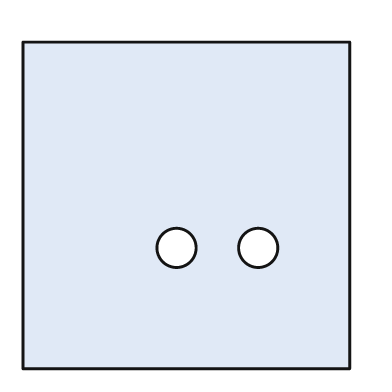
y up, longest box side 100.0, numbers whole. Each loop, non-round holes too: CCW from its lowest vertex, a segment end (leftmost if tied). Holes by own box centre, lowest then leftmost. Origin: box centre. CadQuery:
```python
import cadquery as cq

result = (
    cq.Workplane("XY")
    .moveTo(-50.0, -50.0)
    .lineTo(50.0, -50.0)
    .lineTo(50.0, 50.0)
    .lineTo(-50.0, 50.0)
    .close()
    .moveTo(-3.0, -13.0)
    .circle(6.0)
    .moveTo(22.0, -13.0)
    .circle(6.0)
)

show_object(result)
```